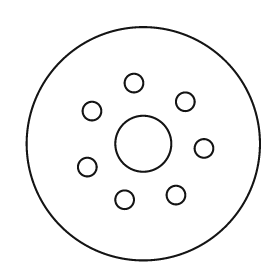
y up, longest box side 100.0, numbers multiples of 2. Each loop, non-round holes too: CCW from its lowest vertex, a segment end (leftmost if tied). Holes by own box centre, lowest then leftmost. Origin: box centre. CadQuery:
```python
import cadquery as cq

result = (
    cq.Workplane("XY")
    .moveTo(0.0, 0.0)
    .circle(50.0)
    .moveTo(-8.0, -24.0)
    .circle(4.0)
    .moveTo(14.0, -22.0)
    .circle(4.0)
    .moveTo(-24.0, -10.0)
    .circle(4.0)
    .moveTo(26.0, -2.0)
    .circle(4.0)
    .moveTo(0.0, 0.0)
    .circle(12.0)
    .moveTo(-22.0, 14.0)
    .circle(4.0)
    .moveTo(18.0, 18.0)
    .circle(4.0)
    .moveTo(-4.0, 26.0)
    .circle(4.0)
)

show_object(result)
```